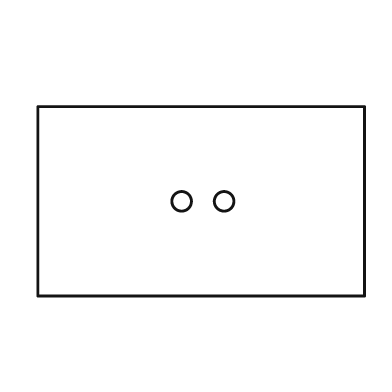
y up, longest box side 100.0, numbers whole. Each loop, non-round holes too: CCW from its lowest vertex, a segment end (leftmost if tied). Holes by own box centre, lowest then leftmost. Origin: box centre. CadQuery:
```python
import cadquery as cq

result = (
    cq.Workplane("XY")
    .moveTo(-50.0, -29.0)
    .lineTo(50.0, -29.0)
    .lineTo(50.0, 29.0)
    .lineTo(-50.0, 29.0)
    .close()
    .moveTo(-6.0, 0.0)
    .circle(3.0)
    .moveTo(7.0, 0.0)
    .circle(3.0)
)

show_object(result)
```